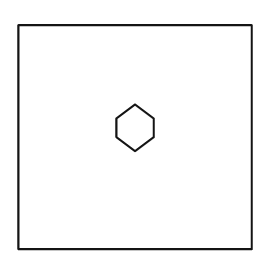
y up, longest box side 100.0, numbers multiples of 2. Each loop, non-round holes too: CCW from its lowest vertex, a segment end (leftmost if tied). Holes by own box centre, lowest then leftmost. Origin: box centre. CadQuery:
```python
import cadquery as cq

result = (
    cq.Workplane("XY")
    .moveTo(-50.0, -48.0)
    .lineTo(50.0, -48.0)
    .lineTo(50.0, 48.0)
    .lineTo(-50.0, 48.0)
    .close()
    .moveTo(0.0, -6.0)
    .lineTo(8.0, 0.0)
    .lineTo(8.0, 8.0)
    .lineTo(0.0, 14.0)
    .lineTo(-8.0, 8.0)
    .lineTo(-8.0, 0.0)
    .close()
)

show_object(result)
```